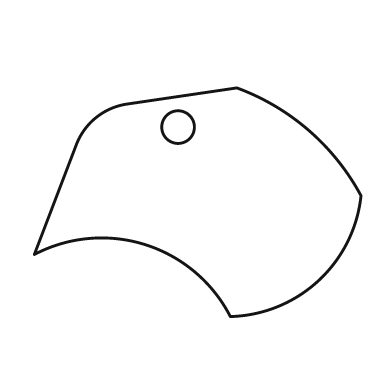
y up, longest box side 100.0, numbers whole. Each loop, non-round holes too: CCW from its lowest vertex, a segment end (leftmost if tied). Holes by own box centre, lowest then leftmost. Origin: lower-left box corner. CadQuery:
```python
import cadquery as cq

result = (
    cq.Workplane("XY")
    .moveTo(60.0, 0.0)
    .threePointArc((87.0, 11.0), (100.0, 37.0))
    .threePointArc((84.0, 57.0), (62.0, 70.0))
    .lineTo(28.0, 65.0)
    .threePointArc((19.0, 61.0), (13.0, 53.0))
    .lineTo(0.0, 19.0)
    .threePointArc((34.0, 22.0), (60.0, 0.0))
    .close()
    .moveTo(44.0, 58.0)
    .circle(5.0)
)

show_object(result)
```